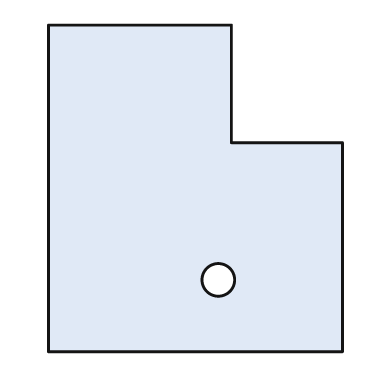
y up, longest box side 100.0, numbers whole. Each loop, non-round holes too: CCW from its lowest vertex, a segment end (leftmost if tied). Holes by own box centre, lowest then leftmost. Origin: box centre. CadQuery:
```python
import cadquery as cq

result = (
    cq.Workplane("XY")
    .moveTo(-45.0, -50.0)
    .lineTo(45.0, -50.0)
    .lineTo(45.0, 14.0)
    .lineTo(11.0, 14.0)
    .lineTo(11.0, 50.0)
    .lineTo(-45.0, 50.0)
    .close()
    .moveTo(7.0, -28.0)
    .circle(5.0)
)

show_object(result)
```